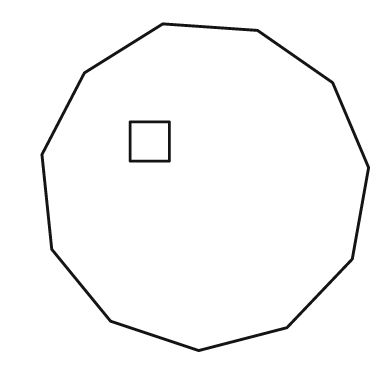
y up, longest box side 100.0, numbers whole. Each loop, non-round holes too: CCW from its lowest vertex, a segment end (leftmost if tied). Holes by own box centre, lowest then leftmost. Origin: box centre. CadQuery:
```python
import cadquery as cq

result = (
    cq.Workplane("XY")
    .moveTo(-2.0, -50.0)
    .lineTo(25.0, -43.0)
    .lineTo(45.0, -22.0)
    .lineTo(50.0, 6.0)
    .lineTo(39.0, 32.0)
    .lineTo(16.0, 48.0)
    .lineTo(-13.0, 50.0)
    .lineTo(-37.0, 35.0)
    .lineTo(-50.0, 10.0)
    .lineTo(-47.0, -19.0)
    .lineTo(-29.0, -41.0)
    .close()
    .moveTo(-23.0, 8.0)
    .lineTo(-11.0, 8.0)
    .lineTo(-11.0, 20.0)
    .lineTo(-23.0, 20.0)
    .close()
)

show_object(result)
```